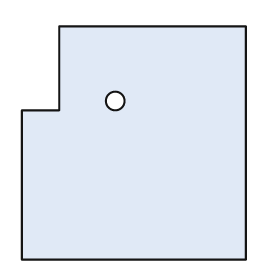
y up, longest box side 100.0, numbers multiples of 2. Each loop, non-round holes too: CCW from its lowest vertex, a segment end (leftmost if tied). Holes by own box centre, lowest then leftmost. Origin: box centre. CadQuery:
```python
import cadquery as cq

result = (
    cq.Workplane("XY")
    .moveTo(-48.0, -50.0)
    .lineTo(48.0, -50.0)
    .lineTo(48.0, 50.0)
    .lineTo(-32.0, 50.0)
    .lineTo(-32.0, 14.0)
    .lineTo(-48.0, 14.0)
    .close()
    .moveTo(-8.0, 18.0)
    .circle(4.0)
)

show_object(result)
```